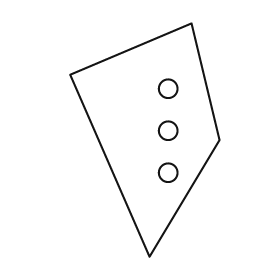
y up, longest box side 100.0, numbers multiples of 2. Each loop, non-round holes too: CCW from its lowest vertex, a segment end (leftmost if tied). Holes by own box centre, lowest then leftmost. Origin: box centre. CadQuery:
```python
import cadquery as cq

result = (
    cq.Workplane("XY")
    .moveTo(2.0, -50.0)
    .lineTo(32.0, 0.0)
    .lineTo(20.0, 50.0)
    .lineTo(-32.0, 28.0)
    .close()
    .moveTo(10.0, -14.0)
    .circle(4.0)
    .moveTo(10.0, 4.0)
    .circle(4.0)
    .moveTo(10.0, 22.0)
    .circle(4.0)
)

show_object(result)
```